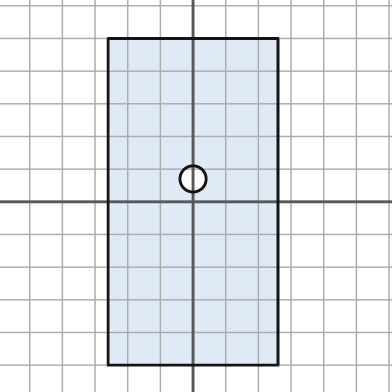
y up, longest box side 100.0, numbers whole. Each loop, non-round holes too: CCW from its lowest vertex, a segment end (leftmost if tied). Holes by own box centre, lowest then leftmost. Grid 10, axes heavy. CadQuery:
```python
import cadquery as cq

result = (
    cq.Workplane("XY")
    .moveTo(-26.0, -50.0)
    .lineTo(26.0, -50.0)
    .lineTo(26.0, 50.0)
    .lineTo(-26.0, 50.0)
    .close()
    .moveTo(0.0, 7.0)
    .circle(4.0)
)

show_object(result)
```